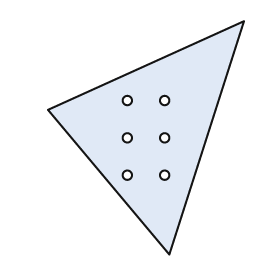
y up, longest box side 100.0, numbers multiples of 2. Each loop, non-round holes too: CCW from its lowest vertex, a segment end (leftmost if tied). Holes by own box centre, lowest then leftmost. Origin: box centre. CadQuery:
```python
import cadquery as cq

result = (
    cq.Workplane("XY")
    .moveTo(10.0, -50.0)
    .lineTo(42.0, 50.0)
    .lineTo(-42.0, 12.0)
    .close()
    .moveTo(-8.0, -16.0)
    .circle(2.0)
    .moveTo(8.0, -16.0)
    .circle(2.0)
    .moveTo(-8.0, 0.0)
    .circle(2.0)
    .moveTo(8.0, 0.0)
    .circle(2.0)
    .moveTo(-8.0, 16.0)
    .circle(2.0)
    .moveTo(8.0, 16.0)
    .circle(2.0)
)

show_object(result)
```